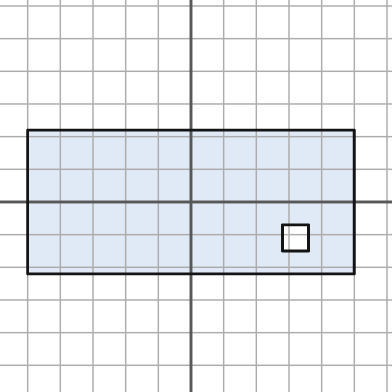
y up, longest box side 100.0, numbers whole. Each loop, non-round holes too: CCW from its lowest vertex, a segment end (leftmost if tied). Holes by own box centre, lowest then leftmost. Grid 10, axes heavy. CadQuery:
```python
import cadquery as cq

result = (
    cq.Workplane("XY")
    .moveTo(-50.0, -22.0)
    .lineTo(50.0, -22.0)
    .lineTo(50.0, 22.0)
    .lineTo(-50.0, 22.0)
    .close()
    .moveTo(28.0, -15.0)
    .lineTo(36.0, -15.0)
    .lineTo(36.0, -7.0)
    .lineTo(28.0, -7.0)
    .close()
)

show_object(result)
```